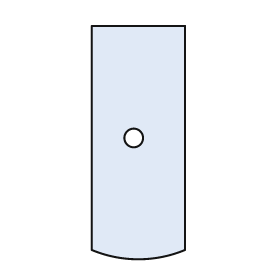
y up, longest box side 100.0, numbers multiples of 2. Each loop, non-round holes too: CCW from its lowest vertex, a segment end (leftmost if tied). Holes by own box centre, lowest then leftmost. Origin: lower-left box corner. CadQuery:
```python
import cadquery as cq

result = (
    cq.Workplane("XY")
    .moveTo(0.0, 4.0)
    .threePointArc((20.0, 0.0), (40.0, 4.0))
    .lineTo(40.0, 100.0)
    .lineTo(0.0, 100.0)
    .close()
    .moveTo(18.0, 52.0)
    .circle(4.0)
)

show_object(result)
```